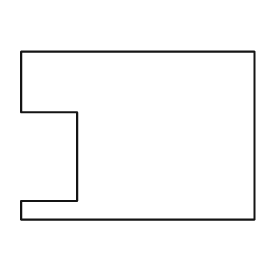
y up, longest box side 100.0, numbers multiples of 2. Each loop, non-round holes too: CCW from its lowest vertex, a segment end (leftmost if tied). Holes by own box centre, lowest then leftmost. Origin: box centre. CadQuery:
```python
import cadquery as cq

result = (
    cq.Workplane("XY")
    .moveTo(-50.0, -36.0)
    .lineTo(50.0, -36.0)
    .lineTo(50.0, 36.0)
    .lineTo(-50.0, 36.0)
    .lineTo(-50.0, 10.0)
    .lineTo(-26.0, 10.0)
    .lineTo(-26.0, -28.0)
    .lineTo(-50.0, -28.0)
    .close()
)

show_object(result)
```